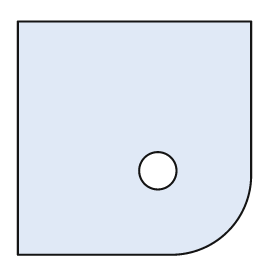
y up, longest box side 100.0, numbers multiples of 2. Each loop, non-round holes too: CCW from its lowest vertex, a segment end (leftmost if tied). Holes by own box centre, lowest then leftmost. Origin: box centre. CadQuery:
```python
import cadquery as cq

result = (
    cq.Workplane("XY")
    .moveTo(-50.0, -50.0)
    .lineTo(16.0, -50.0)
    .threePointArc((40.0, -40.0), (50.0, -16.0))
    .lineTo(50.0, 50.0)
    .lineTo(-50.0, 50.0)
    .close()
    .moveTo(10.0, -14.0)
    .circle(8.0)
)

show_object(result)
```